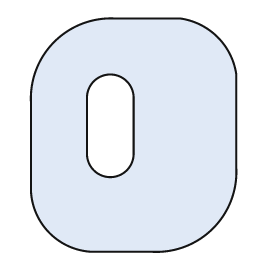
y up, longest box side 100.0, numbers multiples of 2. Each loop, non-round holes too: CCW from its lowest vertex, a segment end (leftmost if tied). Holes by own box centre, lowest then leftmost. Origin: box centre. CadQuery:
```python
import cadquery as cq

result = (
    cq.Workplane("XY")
    .moveTo(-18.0, -50.0)
    .lineTo(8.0, -50.0)
    .threePointArc((34.0, -40.0), (44.0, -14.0))
    .lineTo(44.0, 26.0)
    .threePointArc((36.0, 42.0), (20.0, 50.0))
    .lineTo(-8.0, 50.0)
    .threePointArc((-34.0, 40.0), (-44.0, 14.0))
    .lineTo(-44.0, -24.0)
    .threePointArc((-36.0, -42.0), (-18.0, -50.0))
    .close()
    .moveTo(-20.0, -8.0)
    .threePointArc((-10.0, -18.0), (0.0, -8.0))
    .lineTo(0.0, 16.0)
    .threePointArc((-10.0, 26.0), (-20.0, 16.0))
    .close()
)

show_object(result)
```